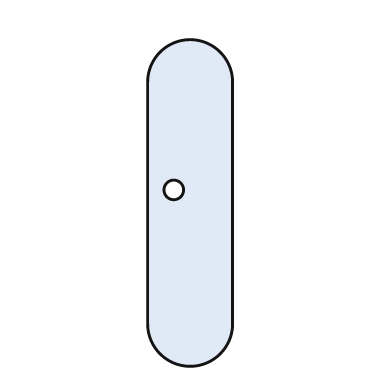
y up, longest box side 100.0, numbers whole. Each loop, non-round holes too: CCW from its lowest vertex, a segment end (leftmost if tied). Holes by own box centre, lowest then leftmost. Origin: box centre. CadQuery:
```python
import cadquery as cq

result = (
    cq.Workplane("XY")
    .moveTo(-13.0, -37.0)
    .threePointArc((0.0, -50.0), (13.0, -37.0))
    .lineTo(13.0, 37.0)
    .threePointArc((0.0, 50.0), (-13.0, 37.0))
    .close()
    .moveTo(-5.0, 4.0)
    .circle(3.0)
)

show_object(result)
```